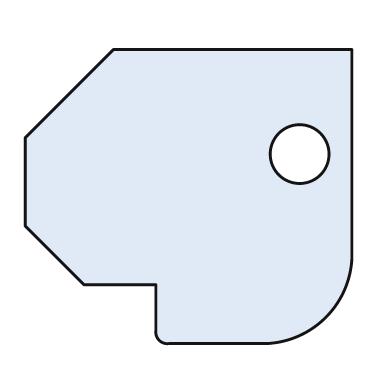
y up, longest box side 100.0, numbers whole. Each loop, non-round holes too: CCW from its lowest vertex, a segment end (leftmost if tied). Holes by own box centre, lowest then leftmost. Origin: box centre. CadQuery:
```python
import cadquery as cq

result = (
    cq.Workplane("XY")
    .moveTo(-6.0, -45.0)
    .lineTo(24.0, -45.0)
    .threePointArc((42.0, -37.0), (50.0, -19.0))
    .lineTo(50.0, 45.0)
    .lineTo(-23.0, 45.0)
    .lineTo(-50.0, 18.0)
    .lineTo(-50.0, -9.0)
    .lineTo(-32.0, -27.0)
    .lineTo(-10.0, -27.0)
    .lineTo(-10.0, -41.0)
    .threePointArc((-9.0, -44.0), (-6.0, -45.0))
    .close()
    .moveTo(34.0, 13.0)
    .circle(9.0)
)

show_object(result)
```